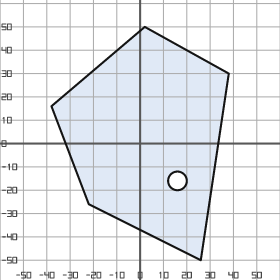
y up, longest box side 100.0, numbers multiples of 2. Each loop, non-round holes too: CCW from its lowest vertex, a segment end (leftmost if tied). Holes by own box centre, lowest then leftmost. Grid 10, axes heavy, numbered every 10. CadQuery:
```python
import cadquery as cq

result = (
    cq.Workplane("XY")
    .moveTo(26.0, -50.0)
    .lineTo(38.0, 30.0)
    .lineTo(2.0, 50.0)
    .lineTo(-38.0, 16.0)
    .lineTo(-22.0, -26.0)
    .close()
    .moveTo(16.0, -16.0)
    .circle(4.0)
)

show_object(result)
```